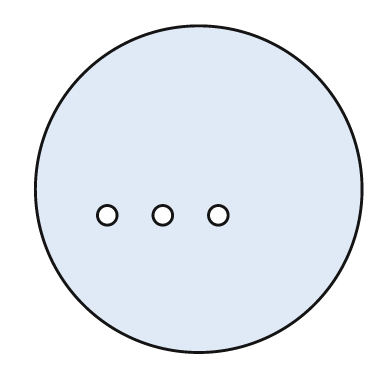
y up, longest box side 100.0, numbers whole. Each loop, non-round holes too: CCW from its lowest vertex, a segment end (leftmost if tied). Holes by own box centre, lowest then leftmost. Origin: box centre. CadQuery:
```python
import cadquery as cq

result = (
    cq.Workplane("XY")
    .moveTo(0.0, 0.0)
    .circle(50.0)
    .moveTo(-28.0, -8.0)
    .circle(3.0)
    .moveTo(-11.0, -8.0)
    .circle(3.0)
    .moveTo(6.0, -8.0)
    .circle(3.0)
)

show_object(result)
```